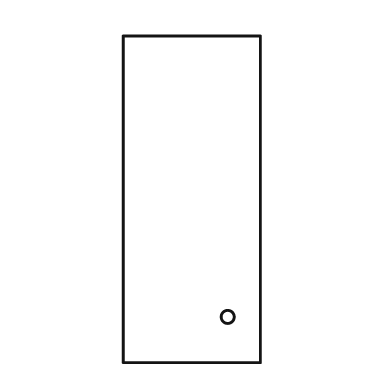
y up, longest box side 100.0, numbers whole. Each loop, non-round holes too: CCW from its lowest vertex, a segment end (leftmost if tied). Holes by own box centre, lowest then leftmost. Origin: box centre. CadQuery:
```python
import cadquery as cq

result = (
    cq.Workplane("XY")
    .moveTo(-21.0, -50.0)
    .lineTo(21.0, -50.0)
    .lineTo(21.0, 50.0)
    .lineTo(-21.0, 50.0)
    .close()
    .moveTo(11.0, -36.0)
    .circle(2.0)
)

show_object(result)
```